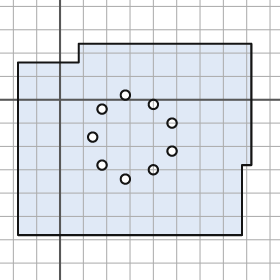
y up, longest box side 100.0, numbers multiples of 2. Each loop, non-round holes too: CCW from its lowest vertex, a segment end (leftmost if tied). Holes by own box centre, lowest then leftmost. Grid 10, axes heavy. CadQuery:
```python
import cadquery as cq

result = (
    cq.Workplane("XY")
    .moveTo(-18.0, -58.0)
    .lineTo(78.0, -58.0)
    .lineTo(78.0, -28.0)
    .lineTo(82.0, -28.0)
    .lineTo(82.0, 24.0)
    .lineTo(8.0, 24.0)
    .lineTo(8.0, 16.0)
    .lineTo(-18.0, 16.0)
    .close()
    .moveTo(28.0, -34.0)
    .circle(2.0)
    .moveTo(40.0, -30.0)
    .circle(2.0)
    .moveTo(18.0, -28.0)
    .circle(2.0)
    .moveTo(48.0, -22.0)
    .circle(2.0)
    .moveTo(14.0, -16.0)
    .circle(2.0)
    .moveTo(48.0, -10.0)
    .circle(2.0)
    .moveTo(18.0, -4.0)
    .circle(2.0)
    .moveTo(40.0, -2.0)
    .circle(2.0)
    .moveTo(28.0, 2.0)
    .circle(2.0)
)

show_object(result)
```